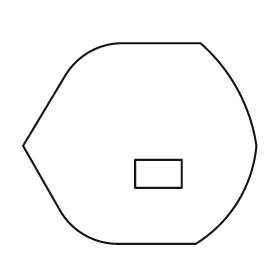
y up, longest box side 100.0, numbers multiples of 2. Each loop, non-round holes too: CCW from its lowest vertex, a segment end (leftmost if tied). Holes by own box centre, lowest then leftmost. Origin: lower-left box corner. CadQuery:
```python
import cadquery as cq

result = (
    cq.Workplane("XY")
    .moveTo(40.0, 0.0)
    .lineTo(74.0, 0.0)
    .threePointArc((92.0, 18.0), (100.0, 42.0))
    .threePointArc((92.0, 66.0), (76.0, 86.0))
    .lineTo(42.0, 86.0)
    .threePointArc((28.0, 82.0), (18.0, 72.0))
    .lineTo(0.0, 42.0)
    .lineTo(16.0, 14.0)
    .threePointArc((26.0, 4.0), (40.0, 0.0))
    .close()
    .moveTo(48.0, 24.0)
    .lineTo(68.0, 24.0)
    .lineTo(68.0, 36.0)
    .lineTo(48.0, 36.0)
    .close()
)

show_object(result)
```